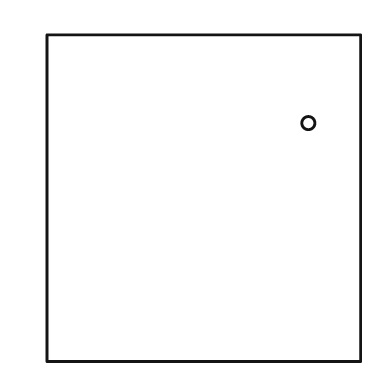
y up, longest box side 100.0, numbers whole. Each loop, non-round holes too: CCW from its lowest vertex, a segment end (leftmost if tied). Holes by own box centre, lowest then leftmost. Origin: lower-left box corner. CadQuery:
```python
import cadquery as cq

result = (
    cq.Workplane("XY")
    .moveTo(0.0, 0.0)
    .lineTo(96.0, 0.0)
    .lineTo(96.0, 100.0)
    .lineTo(0.0, 100.0)
    .close()
    .moveTo(80.0, 73.0)
    .circle(2.0)
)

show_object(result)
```